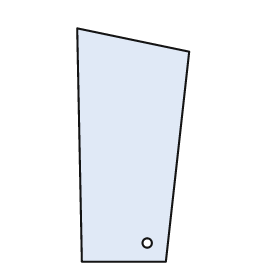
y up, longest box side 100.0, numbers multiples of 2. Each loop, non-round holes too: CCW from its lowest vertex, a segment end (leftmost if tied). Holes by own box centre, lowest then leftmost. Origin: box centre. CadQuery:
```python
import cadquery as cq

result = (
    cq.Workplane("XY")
    .moveTo(-22.0, -50.0)
    .lineTo(14.0, -50.0)
    .lineTo(24.0, 40.0)
    .lineTo(-24.0, 50.0)
    .close()
    .moveTo(6.0, -42.0)
    .circle(2.0)
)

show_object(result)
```